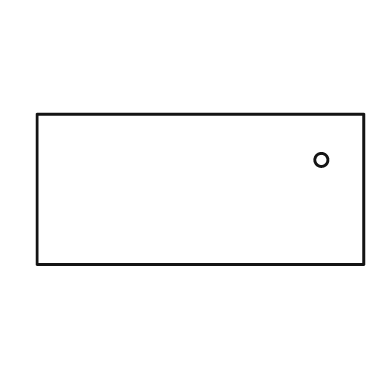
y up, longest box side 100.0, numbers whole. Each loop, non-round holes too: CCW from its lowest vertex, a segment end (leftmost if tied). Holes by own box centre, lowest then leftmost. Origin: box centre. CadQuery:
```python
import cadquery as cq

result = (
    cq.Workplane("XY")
    .moveTo(-50.0, -23.0)
    .lineTo(50.0, -23.0)
    .lineTo(50.0, 23.0)
    .lineTo(-50.0, 23.0)
    .close()
    .moveTo(37.0, 9.0)
    .circle(2.0)
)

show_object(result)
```